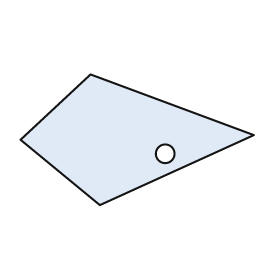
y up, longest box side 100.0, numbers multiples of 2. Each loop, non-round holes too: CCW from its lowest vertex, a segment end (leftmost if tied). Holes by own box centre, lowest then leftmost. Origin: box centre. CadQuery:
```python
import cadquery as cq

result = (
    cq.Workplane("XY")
    .moveTo(-16.0, -28.0)
    .lineTo(50.0, 2.0)
    .lineTo(-20.0, 28.0)
    .lineTo(-50.0, 0.0)
    .close()
    .moveTo(12.0, -6.0)
    .circle(4.0)
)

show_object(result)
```